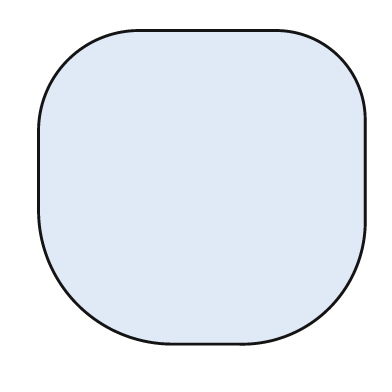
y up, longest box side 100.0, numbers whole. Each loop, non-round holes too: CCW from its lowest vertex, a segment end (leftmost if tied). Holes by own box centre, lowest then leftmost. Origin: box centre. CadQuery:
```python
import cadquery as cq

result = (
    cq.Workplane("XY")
    .moveTo(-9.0, -48.0)
    .lineTo(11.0, -48.0)
    .threePointArc((39.0, -37.0), (50.0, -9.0))
    .lineTo(50.0, 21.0)
    .threePointArc((42.0, 40.0), (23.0, 48.0))
    .lineTo(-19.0, 48.0)
    .threePointArc((-41.0, 39.0), (-50.0, 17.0))
    .lineTo(-50.0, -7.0)
    .threePointArc((-38.0, -36.0), (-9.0, -48.0))
    .close()
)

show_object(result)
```